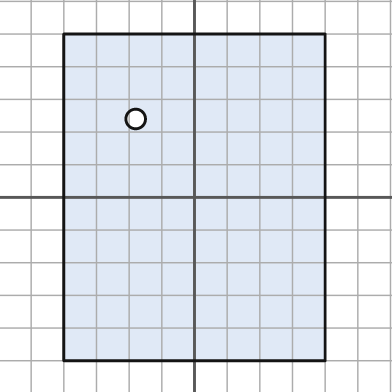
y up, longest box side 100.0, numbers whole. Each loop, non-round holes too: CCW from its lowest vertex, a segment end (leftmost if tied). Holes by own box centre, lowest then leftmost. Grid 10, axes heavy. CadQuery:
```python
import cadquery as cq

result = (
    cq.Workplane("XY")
    .moveTo(-40.0, -50.0)
    .lineTo(40.0, -50.0)
    .lineTo(40.0, 50.0)
    .lineTo(-40.0, 50.0)
    .close()
    .moveTo(-18.0, 24.0)
    .circle(3.0)
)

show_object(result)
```